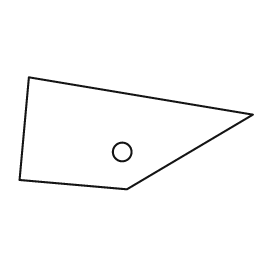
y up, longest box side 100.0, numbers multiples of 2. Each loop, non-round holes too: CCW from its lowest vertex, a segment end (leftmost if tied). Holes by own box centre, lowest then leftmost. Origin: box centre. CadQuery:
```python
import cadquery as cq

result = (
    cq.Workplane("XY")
    .moveTo(-4.0, -24.0)
    .lineTo(50.0, 8.0)
    .lineTo(-46.0, 24.0)
    .lineTo(-50.0, -20.0)
    .close()
    .moveTo(-6.0, -8.0)
    .circle(4.0)
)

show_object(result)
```